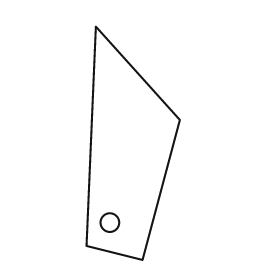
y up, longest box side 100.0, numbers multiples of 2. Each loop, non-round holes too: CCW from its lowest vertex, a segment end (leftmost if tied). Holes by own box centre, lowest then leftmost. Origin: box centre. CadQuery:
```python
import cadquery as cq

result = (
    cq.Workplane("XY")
    .moveTo(4.0, -50.0)
    .lineTo(20.0, 10.0)
    .lineTo(-16.0, 50.0)
    .lineTo(-20.0, -44.0)
    .close()
    .moveTo(-10.0, -34.0)
    .circle(4.0)
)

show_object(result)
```